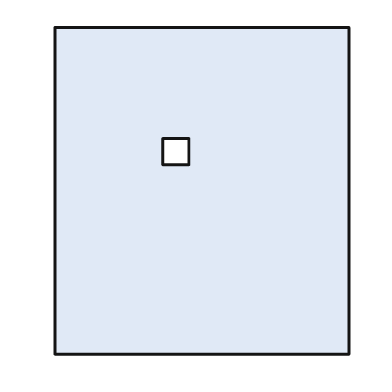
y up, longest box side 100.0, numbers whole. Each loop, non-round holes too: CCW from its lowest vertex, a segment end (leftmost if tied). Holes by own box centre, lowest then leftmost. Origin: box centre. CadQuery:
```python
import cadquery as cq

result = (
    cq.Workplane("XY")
    .moveTo(-45.0, -50.0)
    .lineTo(45.0, -50.0)
    .lineTo(45.0, 50.0)
    .lineTo(-45.0, 50.0)
    .close()
    .moveTo(-12.0, 8.0)
    .lineTo(-4.0, 8.0)
    .lineTo(-4.0, 16.0)
    .lineTo(-12.0, 16.0)
    .close()
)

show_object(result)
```